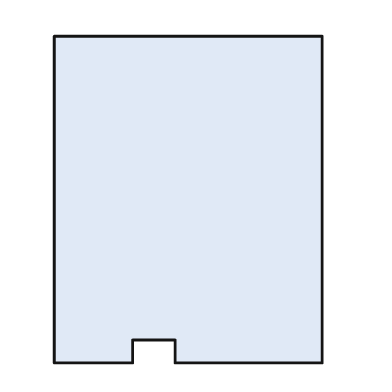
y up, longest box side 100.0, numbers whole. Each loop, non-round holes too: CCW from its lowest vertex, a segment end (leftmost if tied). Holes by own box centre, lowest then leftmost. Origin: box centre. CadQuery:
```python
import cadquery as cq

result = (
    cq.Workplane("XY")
    .moveTo(-41.0, -50.0)
    .lineTo(-17.0, -50.0)
    .lineTo(-17.0, -43.0)
    .lineTo(-4.0, -43.0)
    .lineTo(-4.0, -50.0)
    .lineTo(41.0, -50.0)
    .lineTo(41.0, 50.0)
    .lineTo(-41.0, 50.0)
    .close()
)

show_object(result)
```